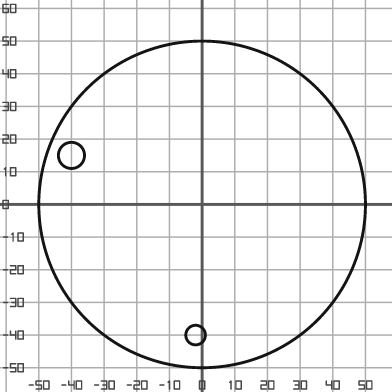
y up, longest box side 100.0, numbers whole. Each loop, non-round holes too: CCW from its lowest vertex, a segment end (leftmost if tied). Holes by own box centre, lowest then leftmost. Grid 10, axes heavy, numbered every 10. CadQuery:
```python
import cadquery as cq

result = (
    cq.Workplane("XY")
    .moveTo(0.0, 0.0)
    .circle(50.0)
    .moveTo(-2.0, -40.0)
    .circle(3.0)
    .moveTo(-40.0, 15.0)
    .circle(4.0)
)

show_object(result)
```